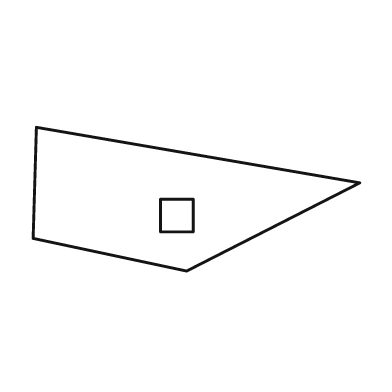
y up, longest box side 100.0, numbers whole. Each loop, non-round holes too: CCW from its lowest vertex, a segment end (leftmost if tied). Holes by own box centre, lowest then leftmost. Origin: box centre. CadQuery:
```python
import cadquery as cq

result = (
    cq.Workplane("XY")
    .moveTo(-3.0, -22.0)
    .lineTo(50.0, 5.0)
    .lineTo(-49.0, 22.0)
    .lineTo(-50.0, -12.0)
    .close()
    .moveTo(-11.0, -10.0)
    .lineTo(-1.0, -10.0)
    .lineTo(-1.0, 0.0)
    .lineTo(-11.0, 0.0)
    .close()
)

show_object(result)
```